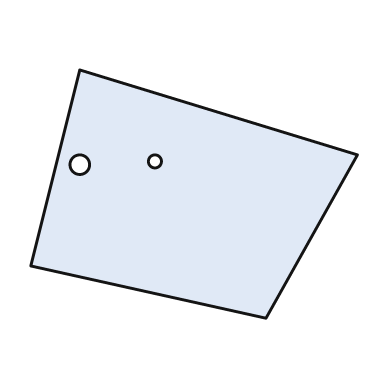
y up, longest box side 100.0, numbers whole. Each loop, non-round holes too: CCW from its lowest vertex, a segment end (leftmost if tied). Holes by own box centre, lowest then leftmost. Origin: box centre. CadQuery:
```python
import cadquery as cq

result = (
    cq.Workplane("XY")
    .moveTo(22.0, -38.0)
    .lineTo(50.0, 12.0)
    .lineTo(-35.0, 38.0)
    .lineTo(-50.0, -22.0)
    .close()
    .moveTo(-35.0, 9.0)
    .circle(3.0)
    .moveTo(-12.0, 10.0)
    .circle(2.0)
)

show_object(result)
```